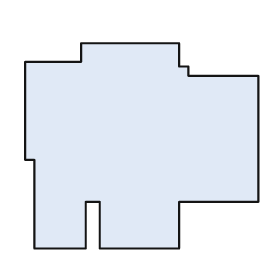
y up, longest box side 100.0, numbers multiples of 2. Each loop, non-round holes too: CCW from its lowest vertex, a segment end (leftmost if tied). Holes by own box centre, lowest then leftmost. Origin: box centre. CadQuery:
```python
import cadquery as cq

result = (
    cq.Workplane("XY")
    .moveTo(-46.0, -44.0)
    .lineTo(-24.0, -44.0)
    .lineTo(-24.0, -24.0)
    .lineTo(-18.0, -24.0)
    .lineTo(-18.0, -44.0)
    .lineTo(16.0, -44.0)
    .lineTo(16.0, -24.0)
    .lineTo(50.0, -24.0)
    .lineTo(50.0, 30.0)
    .lineTo(20.0, 30.0)
    .lineTo(20.0, 34.0)
    .lineTo(16.0, 34.0)
    .lineTo(16.0, 44.0)
    .lineTo(-26.0, 44.0)
    .lineTo(-26.0, 36.0)
    .lineTo(-50.0, 36.0)
    .lineTo(-50.0, -6.0)
    .lineTo(-46.0, -6.0)
    .close()
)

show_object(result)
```